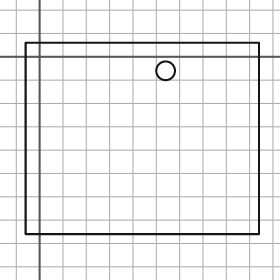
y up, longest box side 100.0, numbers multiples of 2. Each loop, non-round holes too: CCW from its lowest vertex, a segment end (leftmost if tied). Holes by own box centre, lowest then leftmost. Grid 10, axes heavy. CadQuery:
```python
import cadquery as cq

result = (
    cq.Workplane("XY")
    .moveTo(-6.0, -76.0)
    .lineTo(94.0, -76.0)
    .lineTo(94.0, 6.0)
    .lineTo(-6.0, 6.0)
    .close()
    .moveTo(54.0, -6.0)
    .circle(4.0)
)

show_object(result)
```